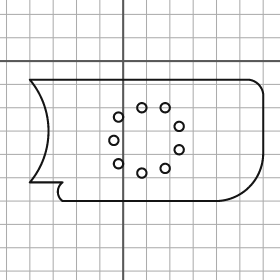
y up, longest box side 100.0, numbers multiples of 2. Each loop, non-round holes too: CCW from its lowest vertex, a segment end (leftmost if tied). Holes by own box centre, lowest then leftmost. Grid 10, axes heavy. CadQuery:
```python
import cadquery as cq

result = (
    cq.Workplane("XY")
    .moveTo(-26.0, -60.0)
    .lineTo(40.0, -60.0)
    .threePointArc((54.0, -54.0), (60.0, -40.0))
    .lineTo(60.0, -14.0)
    .threePointArc((58.0, -10.0), (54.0, -8.0))
    .lineTo(-40.0, -8.0)
    .threePointArc((-32.0, -30.0), (-40.0, -52.0))
    .lineTo(-26.0, -52.0)
    .threePointArc((-28.0, -56.0), (-26.0, -60.0))
    .close()
    .moveTo(8.0, -48.0)
    .circle(2.0)
    .moveTo(18.0, -46.0)
    .circle(2.0)
    .moveTo(-2.0, -44.0)
    .circle(2.0)
    .moveTo(24.0, -38.0)
    .circle(2.0)
    .moveTo(-4.0, -34.0)
    .circle(2.0)
    .moveTo(24.0, -28.0)
    .circle(2.0)
    .moveTo(-2.0, -24.0)
    .circle(2.0)
    .moveTo(8.0, -20.0)
    .circle(2.0)
    .moveTo(18.0, -20.0)
    .circle(2.0)
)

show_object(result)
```